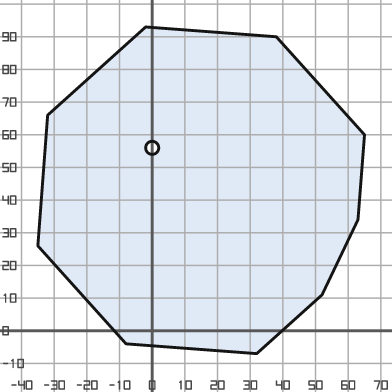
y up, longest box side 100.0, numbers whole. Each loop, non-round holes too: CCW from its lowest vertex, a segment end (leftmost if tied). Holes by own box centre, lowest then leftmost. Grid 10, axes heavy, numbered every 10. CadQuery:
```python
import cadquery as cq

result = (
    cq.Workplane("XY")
    .moveTo(32.0, -7.0)
    .lineTo(52.0, 11.0)
    .lineTo(63.0, 34.0)
    .lineTo(65.0, 60.0)
    .lineTo(38.0, 90.0)
    .lineTo(-2.0, 93.0)
    .lineTo(-32.0, 66.0)
    .lineTo(-35.0, 26.0)
    .lineTo(-8.0, -4.0)
    .close()
    .moveTo(0.0, 56.0)
    .circle(2.0)
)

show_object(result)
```